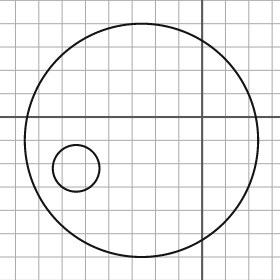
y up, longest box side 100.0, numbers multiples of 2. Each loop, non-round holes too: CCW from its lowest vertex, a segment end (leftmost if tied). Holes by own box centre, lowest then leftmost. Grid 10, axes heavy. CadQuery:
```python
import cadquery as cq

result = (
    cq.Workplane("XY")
    .moveTo(-26.0, -10.0)
    .circle(50.0)
    .moveTo(-54.0, -22.0)
    .circle(10.0)
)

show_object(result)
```